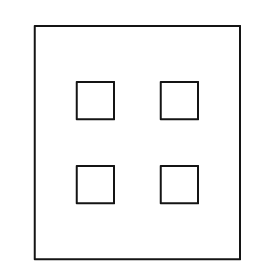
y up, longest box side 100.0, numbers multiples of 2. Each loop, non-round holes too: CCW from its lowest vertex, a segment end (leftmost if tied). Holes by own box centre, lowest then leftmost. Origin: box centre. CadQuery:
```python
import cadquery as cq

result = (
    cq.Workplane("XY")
    .moveTo(-44.0, -50.0)
    .lineTo(44.0, -50.0)
    .lineTo(44.0, 50.0)
    .lineTo(-44.0, 50.0)
    .close()
    .moveTo(-26.0, -26.0)
    .lineTo(-10.0, -26.0)
    .lineTo(-10.0, -10.0)
    .lineTo(-26.0, -10.0)
    .close()
    .moveTo(10.0, -26.0)
    .lineTo(26.0, -26.0)
    .lineTo(26.0, -10.0)
    .lineTo(10.0, -10.0)
    .close()
    .moveTo(-26.0, 10.0)
    .lineTo(-10.0, 10.0)
    .lineTo(-10.0, 26.0)
    .lineTo(-26.0, 26.0)
    .close()
    .moveTo(10.0, 10.0)
    .lineTo(26.0, 10.0)
    .lineTo(26.0, 26.0)
    .lineTo(10.0, 26.0)
    .close()
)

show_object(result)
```